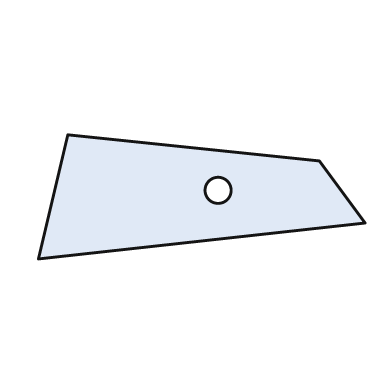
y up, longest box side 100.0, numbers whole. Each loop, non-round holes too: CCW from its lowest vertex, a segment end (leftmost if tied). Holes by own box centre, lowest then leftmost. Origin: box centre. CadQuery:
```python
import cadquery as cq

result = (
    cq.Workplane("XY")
    .moveTo(-50.0, -19.0)
    .lineTo(50.0, -8.0)
    .lineTo(36.0, 11.0)
    .lineTo(-41.0, 19.0)
    .close()
    .moveTo(5.0, 2.0)
    .circle(4.0)
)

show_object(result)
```